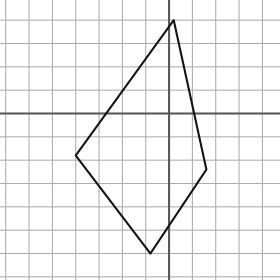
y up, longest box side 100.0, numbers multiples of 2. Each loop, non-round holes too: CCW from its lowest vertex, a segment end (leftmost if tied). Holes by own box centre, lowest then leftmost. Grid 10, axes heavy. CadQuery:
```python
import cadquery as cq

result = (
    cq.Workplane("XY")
    .moveTo(-8.0, -60.0)
    .lineTo(16.0, -24.0)
    .lineTo(2.0, 40.0)
    .lineTo(-40.0, -18.0)
    .close()
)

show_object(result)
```